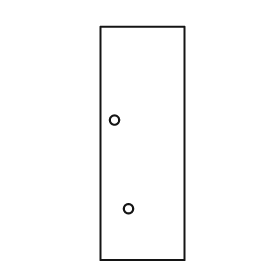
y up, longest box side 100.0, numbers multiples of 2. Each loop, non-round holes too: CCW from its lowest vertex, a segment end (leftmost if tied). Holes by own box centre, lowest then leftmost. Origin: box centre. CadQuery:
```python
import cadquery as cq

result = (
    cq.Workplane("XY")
    .moveTo(-18.0, -50.0)
    .lineTo(18.0, -50.0)
    .lineTo(18.0, 50.0)
    .lineTo(-18.0, 50.0)
    .close()
    .moveTo(-6.0, -28.0)
    .circle(2.0)
    .moveTo(-12.0, 10.0)
    .circle(2.0)
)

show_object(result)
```